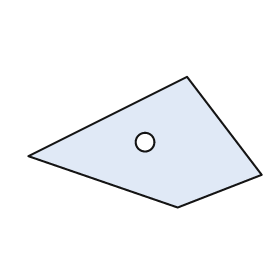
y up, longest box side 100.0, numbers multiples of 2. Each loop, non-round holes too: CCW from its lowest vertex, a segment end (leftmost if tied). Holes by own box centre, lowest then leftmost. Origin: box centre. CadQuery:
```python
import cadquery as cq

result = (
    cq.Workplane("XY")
    .moveTo(14.0, -28.0)
    .lineTo(50.0, -14.0)
    .lineTo(18.0, 28.0)
    .lineTo(-50.0, -6.0)
    .close()
    .moveTo(0.0, 0.0)
    .circle(4.0)
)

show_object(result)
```